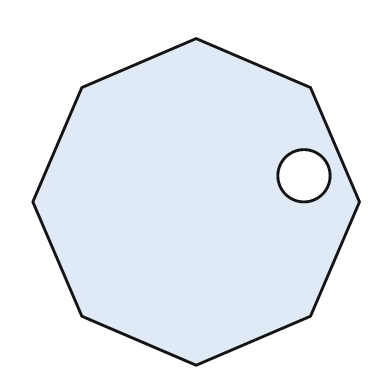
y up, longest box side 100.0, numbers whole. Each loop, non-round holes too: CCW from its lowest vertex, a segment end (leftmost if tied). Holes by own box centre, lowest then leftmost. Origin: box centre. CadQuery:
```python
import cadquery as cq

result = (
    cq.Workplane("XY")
    .moveTo(0.0, -50.0)
    .lineTo(35.0, -35.0)
    .lineTo(50.0, 0.0)
    .lineTo(35.0, 35.0)
    .lineTo(0.0, 50.0)
    .lineTo(-35.0, 35.0)
    .lineTo(-50.0, 0.0)
    .lineTo(-35.0, -35.0)
    .close()
    .moveTo(33.0, 8.0)
    .circle(8.0)
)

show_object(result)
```